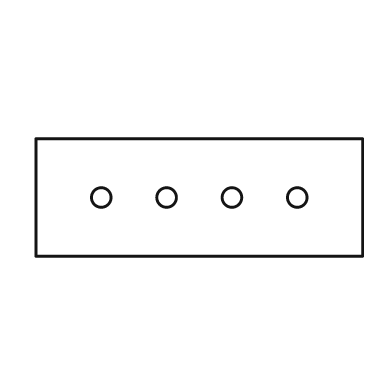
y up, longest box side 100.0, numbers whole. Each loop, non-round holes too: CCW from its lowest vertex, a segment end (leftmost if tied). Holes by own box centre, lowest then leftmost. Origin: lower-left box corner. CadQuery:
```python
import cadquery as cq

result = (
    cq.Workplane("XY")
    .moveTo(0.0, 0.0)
    .lineTo(100.0, 0.0)
    .lineTo(100.0, 36.0)
    .lineTo(0.0, 36.0)
    .close()
    .moveTo(20.0, 18.0)
    .circle(3.0)
    .moveTo(40.0, 18.0)
    .circle(3.0)
    .moveTo(60.0, 18.0)
    .circle(3.0)
    .moveTo(80.0, 18.0)
    .circle(3.0)
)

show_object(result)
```